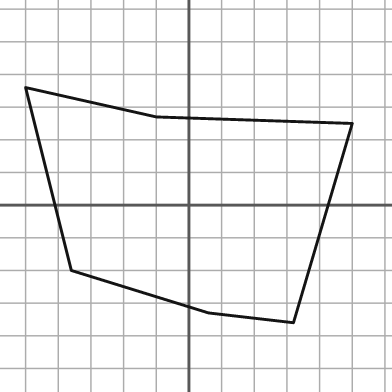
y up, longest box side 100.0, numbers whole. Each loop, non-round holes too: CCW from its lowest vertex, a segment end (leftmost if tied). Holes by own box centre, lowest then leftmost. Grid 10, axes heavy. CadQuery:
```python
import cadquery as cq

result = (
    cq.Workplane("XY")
    .moveTo(32.0, -36.0)
    .lineTo(50.0, 25.0)
    .lineTo(-10.0, 27.0)
    .lineTo(-50.0, 36.0)
    .lineTo(-36.0, -20.0)
    .lineTo(6.0, -33.0)
    .close()
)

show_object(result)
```